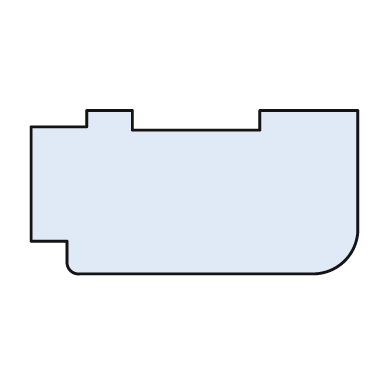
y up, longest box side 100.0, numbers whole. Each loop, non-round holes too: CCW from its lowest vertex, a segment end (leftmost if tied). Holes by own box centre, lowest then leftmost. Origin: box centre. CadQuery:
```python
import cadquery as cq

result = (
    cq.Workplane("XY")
    .moveTo(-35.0, -25.0)
    .lineTo(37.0, -25.0)
    .threePointArc((46.0, -21.0), (50.0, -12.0))
    .lineTo(50.0, 25.0)
    .lineTo(20.0, 25.0)
    .lineTo(20.0, 19.0)
    .lineTo(-19.0, 19.0)
    .lineTo(-19.0, 25.0)
    .lineTo(-33.0, 25.0)
    .lineTo(-33.0, 20.0)
    .lineTo(-50.0, 20.0)
    .lineTo(-50.0, -15.0)
    .lineTo(-39.0, -15.0)
    .lineTo(-39.0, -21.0)
    .threePointArc((-38.0, -24.0), (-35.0, -25.0))
    .close()
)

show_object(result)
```